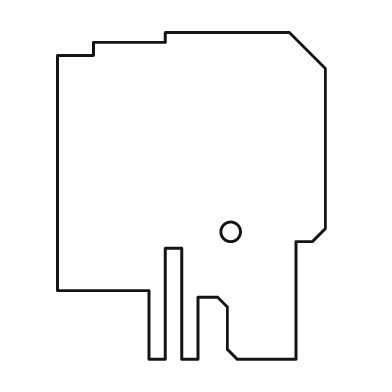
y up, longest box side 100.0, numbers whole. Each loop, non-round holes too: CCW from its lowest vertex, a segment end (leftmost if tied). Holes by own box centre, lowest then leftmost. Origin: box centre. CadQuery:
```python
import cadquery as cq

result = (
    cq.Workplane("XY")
    .moveTo(-13.0, -50.0)
    .lineTo(-8.0, -50.0)
    .lineTo(-8.0, -16.0)
    .lineTo(-3.0, -16.0)
    .lineTo(-3.0, -50.0)
    .lineTo(2.0, -50.0)
    .lineTo(2.0, -31.0)
    .lineTo(8.0, -31.0)
    .lineTo(11.0, -34.0)
    .lineTo(11.0, -47.0)
    .lineTo(14.0, -50.0)
    .lineTo(32.0, -50.0)
    .lineTo(32.0, -14.0)
    .lineTo(37.0, -14.0)
    .lineTo(41.0, -10.0)
    .lineTo(41.0, 39.0)
    .lineTo(30.0, 50.0)
    .lineTo(-8.0, 50.0)
    .lineTo(-8.0, 47.0)
    .lineTo(-30.0, 47.0)
    .lineTo(-30.0, 43.0)
    .lineTo(-41.0, 43.0)
    .lineTo(-41.0, -29.0)
    .lineTo(-13.0, -29.0)
    .close()
    .moveTo(12.0, -11.0)
    .circle(3.0)
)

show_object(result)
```